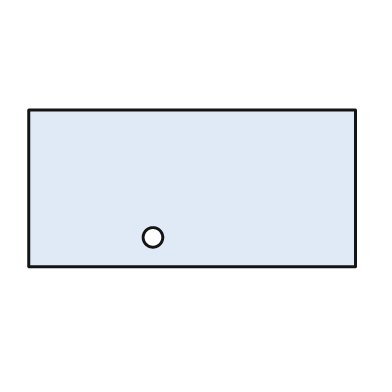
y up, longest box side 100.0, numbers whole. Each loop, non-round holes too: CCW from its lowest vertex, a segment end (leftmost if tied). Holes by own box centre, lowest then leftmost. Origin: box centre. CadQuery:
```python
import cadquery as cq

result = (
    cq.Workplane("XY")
    .moveTo(-50.0, -24.0)
    .lineTo(50.0, -24.0)
    .lineTo(50.0, 24.0)
    .lineTo(-50.0, 24.0)
    .close()
    .moveTo(-12.0, -15.0)
    .circle(3.0)
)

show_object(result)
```